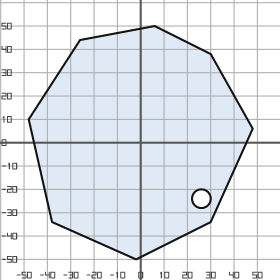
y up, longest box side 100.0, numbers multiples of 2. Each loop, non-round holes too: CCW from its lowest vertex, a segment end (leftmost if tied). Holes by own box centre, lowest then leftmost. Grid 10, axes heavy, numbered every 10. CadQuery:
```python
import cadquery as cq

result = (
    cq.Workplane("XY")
    .moveTo(-2.0, -50.0)
    .lineTo(30.0, -34.0)
    .lineTo(48.0, 6.0)
    .lineTo(30.0, 38.0)
    .lineTo(6.0, 50.0)
    .lineTo(-26.0, 44.0)
    .lineTo(-48.0, 10.0)
    .lineTo(-38.0, -34.0)
    .close()
    .moveTo(26.0, -24.0)
    .circle(4.0)
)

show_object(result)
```